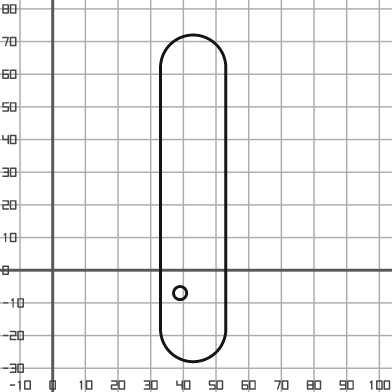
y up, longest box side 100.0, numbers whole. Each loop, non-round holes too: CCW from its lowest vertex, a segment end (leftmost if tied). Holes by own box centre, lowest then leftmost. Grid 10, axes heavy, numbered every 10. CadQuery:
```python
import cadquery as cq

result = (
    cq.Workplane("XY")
    .moveTo(33.0, -18.0)
    .threePointArc((43.0, -28.0), (53.0, -18.0))
    .lineTo(53.0, 62.0)
    .threePointArc((43.0, 72.0), (33.0, 62.0))
    .close()
    .moveTo(39.0, -7.0)
    .circle(2.0)
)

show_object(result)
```